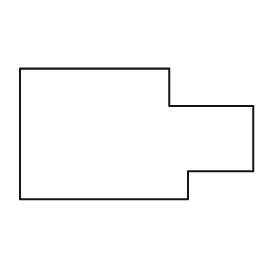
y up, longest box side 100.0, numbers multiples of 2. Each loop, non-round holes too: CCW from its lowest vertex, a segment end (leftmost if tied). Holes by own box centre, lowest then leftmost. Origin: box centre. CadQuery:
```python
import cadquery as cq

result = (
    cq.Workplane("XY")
    .moveTo(-50.0, -28.0)
    .lineTo(22.0, -28.0)
    .lineTo(22.0, -16.0)
    .lineTo(50.0, -16.0)
    .lineTo(50.0, 12.0)
    .lineTo(14.0, 12.0)
    .lineTo(14.0, 28.0)
    .lineTo(-50.0, 28.0)
    .close()
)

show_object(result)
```